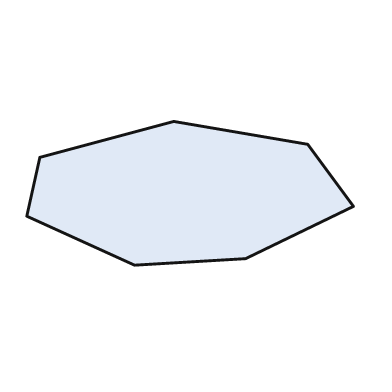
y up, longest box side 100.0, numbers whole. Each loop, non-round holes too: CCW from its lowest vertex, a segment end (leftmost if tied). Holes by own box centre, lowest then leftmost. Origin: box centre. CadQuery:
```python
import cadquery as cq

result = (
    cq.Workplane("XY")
    .moveTo(-17.0, -22.0)
    .lineTo(17.0, -20.0)
    .lineTo(50.0, -4.0)
    .lineTo(36.0, 15.0)
    .lineTo(-5.0, 22.0)
    .lineTo(-46.0, 11.0)
    .lineTo(-50.0, -7.0)
    .close()
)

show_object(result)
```